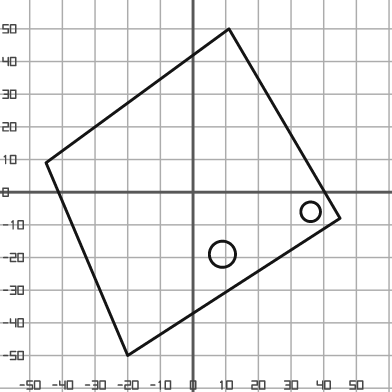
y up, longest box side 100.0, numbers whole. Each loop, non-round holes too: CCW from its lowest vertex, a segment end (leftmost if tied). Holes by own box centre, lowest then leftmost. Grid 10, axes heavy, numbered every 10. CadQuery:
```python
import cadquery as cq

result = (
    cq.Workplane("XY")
    .moveTo(-20.0, -50.0)
    .lineTo(45.0, -8.0)
    .lineTo(11.0, 50.0)
    .lineTo(-45.0, 9.0)
    .close()
    .moveTo(9.0, -19.0)
    .circle(4.0)
    .moveTo(36.0, -6.0)
    .circle(3.0)
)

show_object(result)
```